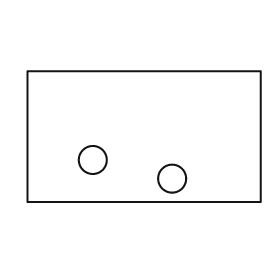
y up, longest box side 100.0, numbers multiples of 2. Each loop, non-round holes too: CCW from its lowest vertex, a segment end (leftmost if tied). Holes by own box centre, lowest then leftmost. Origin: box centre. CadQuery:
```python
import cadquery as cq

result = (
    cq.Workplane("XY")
    .moveTo(-50.0, -28.0)
    .lineTo(50.0, -28.0)
    .lineTo(50.0, 28.0)
    .lineTo(-50.0, 28.0)
    .close()
    .moveTo(12.0, -18.0)
    .circle(6.0)
    .moveTo(-22.0, -10.0)
    .circle(6.0)
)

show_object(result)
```